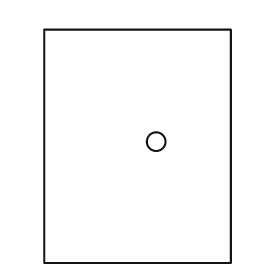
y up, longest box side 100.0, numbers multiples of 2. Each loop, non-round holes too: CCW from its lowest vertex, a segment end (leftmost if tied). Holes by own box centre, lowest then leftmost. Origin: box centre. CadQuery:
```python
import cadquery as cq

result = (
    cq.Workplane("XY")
    .moveTo(-40.0, -50.0)
    .lineTo(40.0, -50.0)
    .lineTo(40.0, 50.0)
    .lineTo(-40.0, 50.0)
    .close()
    .moveTo(8.0, 2.0)
    .circle(4.0)
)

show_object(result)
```